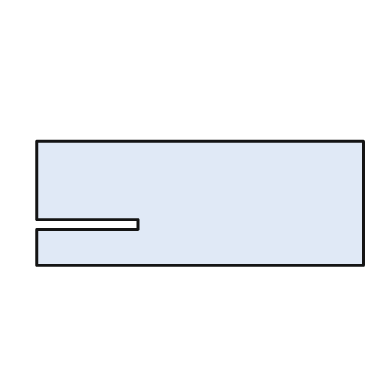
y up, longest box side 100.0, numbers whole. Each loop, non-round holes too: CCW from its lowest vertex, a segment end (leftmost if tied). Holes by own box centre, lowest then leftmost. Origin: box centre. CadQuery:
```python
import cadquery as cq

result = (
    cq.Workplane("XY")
    .moveTo(-50.0, -19.0)
    .lineTo(50.0, -19.0)
    .lineTo(50.0, 19.0)
    .lineTo(-50.0, 19.0)
    .lineTo(-50.0, -5.0)
    .lineTo(-19.0, -5.0)
    .lineTo(-19.0, -8.0)
    .lineTo(-50.0, -8.0)
    .close()
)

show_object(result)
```